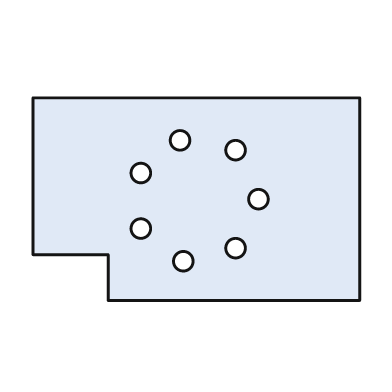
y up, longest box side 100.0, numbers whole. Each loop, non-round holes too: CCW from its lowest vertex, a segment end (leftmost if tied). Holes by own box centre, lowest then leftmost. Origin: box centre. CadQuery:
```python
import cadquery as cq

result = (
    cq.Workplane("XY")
    .moveTo(-27.0, -31.0)
    .lineTo(50.0, -31.0)
    .lineTo(50.0, 31.0)
    .lineTo(-50.0, 31.0)
    .lineTo(-50.0, -17.0)
    .lineTo(-27.0, -17.0)
    .close()
    .moveTo(-4.0, -19.0)
    .circle(3.0)
    .moveTo(12.0, -15.0)
    .circle(3.0)
    .moveTo(-17.0, -9.0)
    .circle(3.0)
    .moveTo(19.0, 0.0)
    .circle(3.0)
    .moveTo(-17.0, 8.0)
    .circle(3.0)
    .moveTo(12.0, 15.0)
    .circle(3.0)
    .moveTo(-5.0, 18.0)
    .circle(3.0)
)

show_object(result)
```